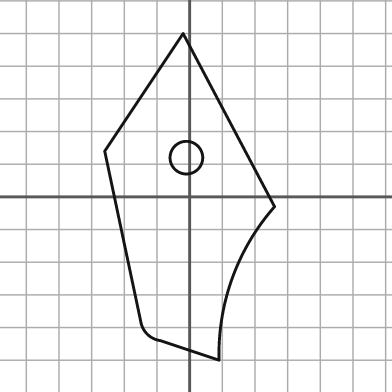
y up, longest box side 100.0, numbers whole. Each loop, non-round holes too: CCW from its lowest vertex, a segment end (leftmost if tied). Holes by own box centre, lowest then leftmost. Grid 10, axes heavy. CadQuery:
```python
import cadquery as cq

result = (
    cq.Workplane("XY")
    .moveTo(9.0, -50.0)
    .threePointArc((13.0, -25.0), (26.0, -3.0))
    .lineTo(-2.0, 50.0)
    .lineTo(-26.0, 14.0)
    .lineTo(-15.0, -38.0)
    .threePointArc((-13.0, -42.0), (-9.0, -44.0))
    .close()
    .moveTo(-1.0, 12.0)
    .circle(5.0)
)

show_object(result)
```